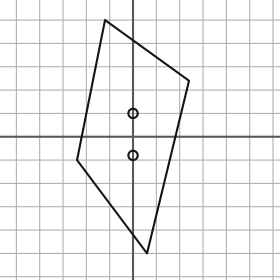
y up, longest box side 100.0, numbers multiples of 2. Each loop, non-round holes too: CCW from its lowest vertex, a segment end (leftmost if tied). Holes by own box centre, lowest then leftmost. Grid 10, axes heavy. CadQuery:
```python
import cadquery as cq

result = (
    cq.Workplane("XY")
    .moveTo(6.0, -50.0)
    .lineTo(24.0, 24.0)
    .lineTo(-12.0, 50.0)
    .lineTo(-24.0, -10.0)
    .close()
    .moveTo(0.0, -8.0)
    .circle(2.0)
    .moveTo(0.0, 10.0)
    .circle(2.0)
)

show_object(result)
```